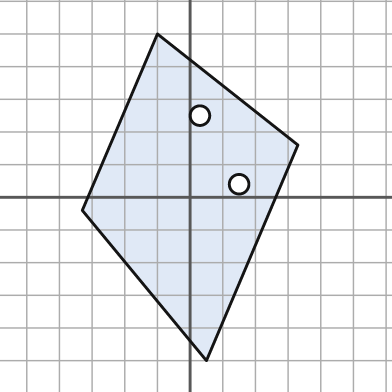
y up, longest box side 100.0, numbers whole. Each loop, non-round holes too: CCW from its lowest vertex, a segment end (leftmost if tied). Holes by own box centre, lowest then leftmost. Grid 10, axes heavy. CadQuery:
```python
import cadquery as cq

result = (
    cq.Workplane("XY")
    .moveTo(5.0, -50.0)
    .lineTo(33.0, 16.0)
    .lineTo(-10.0, 50.0)
    .lineTo(-33.0, -4.0)
    .close()
    .moveTo(15.0, 4.0)
    .circle(3.0)
    .moveTo(3.0, 25.0)
    .circle(3.0)
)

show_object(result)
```